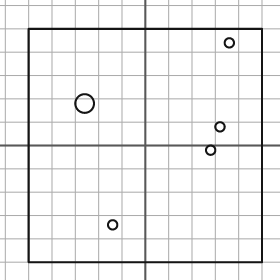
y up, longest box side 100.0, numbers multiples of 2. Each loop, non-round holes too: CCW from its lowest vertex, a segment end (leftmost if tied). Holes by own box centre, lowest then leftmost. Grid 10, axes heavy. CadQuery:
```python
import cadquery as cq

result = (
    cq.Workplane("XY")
    .moveTo(-50.0, -50.0)
    .lineTo(50.0, -50.0)
    .lineTo(50.0, 50.0)
    .lineTo(-50.0, 50.0)
    .close()
    .moveTo(-14.0, -34.0)
    .circle(2.0)
    .moveTo(28.0, -2.0)
    .circle(2.0)
    .moveTo(32.0, 8.0)
    .circle(2.0)
    .moveTo(-26.0, 18.0)
    .circle(4.0)
    .moveTo(36.0, 44.0)
    .circle(2.0)
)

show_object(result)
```